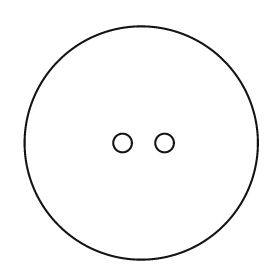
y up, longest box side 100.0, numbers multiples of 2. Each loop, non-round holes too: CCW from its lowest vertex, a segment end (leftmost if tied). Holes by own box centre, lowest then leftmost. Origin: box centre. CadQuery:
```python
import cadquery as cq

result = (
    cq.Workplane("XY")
    .moveTo(0.0, 0.0)
    .circle(50.0)
    .moveTo(-8.0, 0.0)
    .circle(4.0)
    .moveTo(10.0, 0.0)
    .circle(4.0)
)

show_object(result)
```